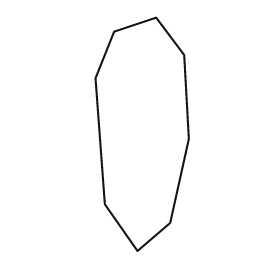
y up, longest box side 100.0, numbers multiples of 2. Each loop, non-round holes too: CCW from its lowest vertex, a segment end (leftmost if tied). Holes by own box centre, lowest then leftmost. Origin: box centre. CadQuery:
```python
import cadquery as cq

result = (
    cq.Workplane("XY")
    .moveTo(-2.0, -50.0)
    .lineTo(12.0, -38.0)
    .lineTo(20.0, -2.0)
    .lineTo(18.0, 34.0)
    .lineTo(6.0, 50.0)
    .lineTo(-12.0, 44.0)
    .lineTo(-20.0, 24.0)
    .lineTo(-16.0, -30.0)
    .close()
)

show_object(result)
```